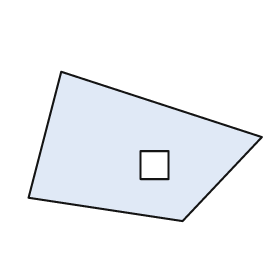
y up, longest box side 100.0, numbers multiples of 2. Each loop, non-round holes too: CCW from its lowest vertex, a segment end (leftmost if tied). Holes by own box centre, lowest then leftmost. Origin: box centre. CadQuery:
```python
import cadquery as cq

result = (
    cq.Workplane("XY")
    .moveTo(16.0, -32.0)
    .lineTo(50.0, 4.0)
    .lineTo(-36.0, 32.0)
    .lineTo(-50.0, -22.0)
    .close()
    .moveTo(-2.0, -14.0)
    .lineTo(10.0, -14.0)
    .lineTo(10.0, -2.0)
    .lineTo(-2.0, -2.0)
    .close()
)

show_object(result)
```